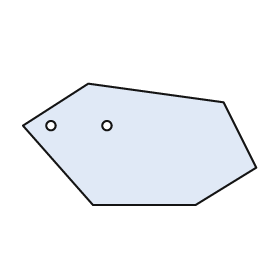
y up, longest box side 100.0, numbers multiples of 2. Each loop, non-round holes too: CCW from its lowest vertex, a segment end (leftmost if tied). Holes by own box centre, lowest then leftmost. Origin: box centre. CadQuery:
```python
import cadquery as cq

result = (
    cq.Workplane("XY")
    .moveTo(-20.0, -26.0)
    .lineTo(24.0, -26.0)
    .lineTo(50.0, -10.0)
    .lineTo(36.0, 18.0)
    .lineTo(-22.0, 26.0)
    .lineTo(-50.0, 8.0)
    .close()
    .moveTo(-38.0, 8.0)
    .circle(2.0)
    .moveTo(-14.0, 8.0)
    .circle(2.0)
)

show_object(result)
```